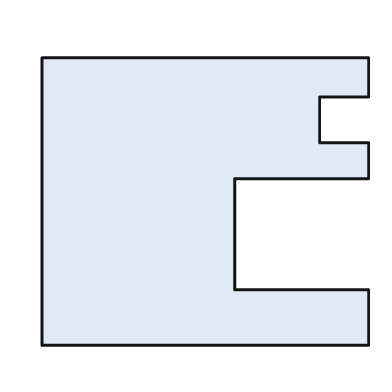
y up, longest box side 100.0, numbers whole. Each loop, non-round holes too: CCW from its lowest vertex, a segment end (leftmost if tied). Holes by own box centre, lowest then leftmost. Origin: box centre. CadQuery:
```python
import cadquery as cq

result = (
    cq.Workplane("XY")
    .moveTo(-50.0, -44.0)
    .lineTo(50.0, -44.0)
    .lineTo(50.0, -27.0)
    .lineTo(9.0, -27.0)
    .lineTo(9.0, 7.0)
    .lineTo(50.0, 7.0)
    .lineTo(50.0, 18.0)
    .lineTo(35.0, 18.0)
    .lineTo(35.0, 32.0)
    .lineTo(50.0, 32.0)
    .lineTo(50.0, 44.0)
    .lineTo(-50.0, 44.0)
    .close()
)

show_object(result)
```